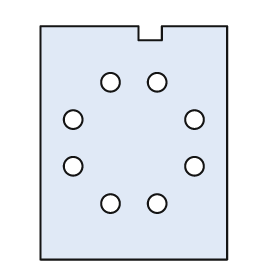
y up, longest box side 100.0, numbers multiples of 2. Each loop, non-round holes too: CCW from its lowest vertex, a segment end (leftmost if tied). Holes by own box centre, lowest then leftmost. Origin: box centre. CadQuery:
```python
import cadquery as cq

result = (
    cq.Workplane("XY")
    .moveTo(-40.0, -50.0)
    .lineTo(40.0, -50.0)
    .lineTo(40.0, 50.0)
    .lineTo(12.0, 50.0)
    .lineTo(12.0, 44.0)
    .lineTo(2.0, 44.0)
    .lineTo(2.0, 50.0)
    .lineTo(-40.0, 50.0)
    .close()
    .moveTo(-10.0, -26.0)
    .circle(4.0)
    .moveTo(10.0, -26.0)
    .circle(4.0)
    .moveTo(-26.0, -10.0)
    .circle(4.0)
    .moveTo(26.0, -10.0)
    .circle(4.0)
    .moveTo(-26.0, 10.0)
    .circle(4.0)
    .moveTo(26.0, 10.0)
    .circle(4.0)
    .moveTo(-10.0, 26.0)
    .circle(4.0)
    .moveTo(10.0, 26.0)
    .circle(4.0)
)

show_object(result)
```